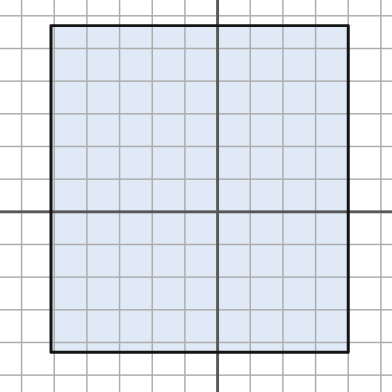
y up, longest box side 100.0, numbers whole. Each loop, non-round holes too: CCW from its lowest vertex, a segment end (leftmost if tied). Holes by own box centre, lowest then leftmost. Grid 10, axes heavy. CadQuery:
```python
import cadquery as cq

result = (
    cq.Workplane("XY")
    .moveTo(-51.0, -43.0)
    .lineTo(40.0, -43.0)
    .lineTo(40.0, 57.0)
    .lineTo(-51.0, 57.0)
    .close()
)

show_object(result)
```